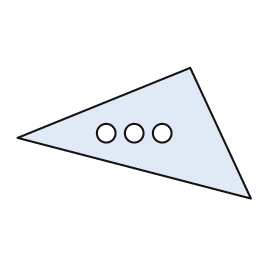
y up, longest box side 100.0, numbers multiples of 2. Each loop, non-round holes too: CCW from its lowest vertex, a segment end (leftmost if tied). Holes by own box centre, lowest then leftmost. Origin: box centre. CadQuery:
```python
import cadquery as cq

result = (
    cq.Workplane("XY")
    .moveTo(50.0, -28.0)
    .lineTo(24.0, 28.0)
    .lineTo(-50.0, -2.0)
    .close()
    .moveTo(-12.0, 0.0)
    .circle(4.0)
    .moveTo(0.0, 0.0)
    .circle(4.0)
    .moveTo(12.0, 0.0)
    .circle(4.0)
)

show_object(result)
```